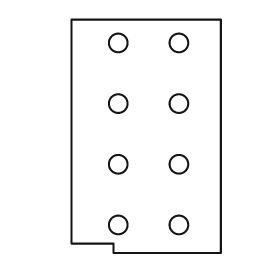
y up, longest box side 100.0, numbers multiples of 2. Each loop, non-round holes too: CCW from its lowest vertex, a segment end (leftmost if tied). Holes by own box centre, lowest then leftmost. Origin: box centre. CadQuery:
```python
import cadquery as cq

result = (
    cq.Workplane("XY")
    .moveTo(-14.0, -50.0)
    .lineTo(32.0, -50.0)
    .lineTo(32.0, 50.0)
    .lineTo(-32.0, 50.0)
    .lineTo(-32.0, -46.0)
    .lineTo(-14.0, -46.0)
    .close()
    .moveTo(-12.0, -38.0)
    .circle(4.0)
    .moveTo(14.0, -38.0)
    .circle(4.0)
    .moveTo(-12.0, -12.0)
    .circle(4.0)
    .moveTo(14.0, -12.0)
    .circle(4.0)
    .moveTo(-12.0, 14.0)
    .circle(4.0)
    .moveTo(14.0, 14.0)
    .circle(4.0)
    .moveTo(-12.0, 40.0)
    .circle(4.0)
    .moveTo(14.0, 40.0)
    .circle(4.0)
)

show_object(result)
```